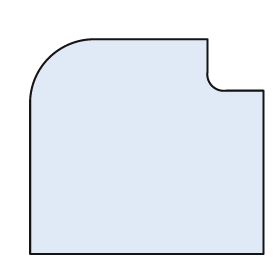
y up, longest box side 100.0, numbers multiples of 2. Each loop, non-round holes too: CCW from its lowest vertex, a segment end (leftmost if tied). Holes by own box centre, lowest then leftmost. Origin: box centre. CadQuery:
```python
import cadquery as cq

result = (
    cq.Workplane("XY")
    .moveTo(-50.0, -46.0)
    .lineTo(50.0, -46.0)
    .lineTo(50.0, 24.0)
    .lineTo(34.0, 24.0)
    .threePointArc((28.0, 26.0), (26.0, 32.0))
    .lineTo(26.0, 46.0)
    .lineTo(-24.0, 46.0)
    .threePointArc((-42.0, 38.0), (-50.0, 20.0))
    .close()
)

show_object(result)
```